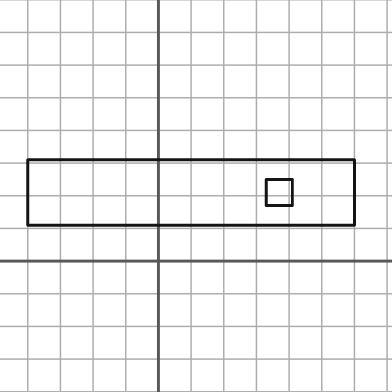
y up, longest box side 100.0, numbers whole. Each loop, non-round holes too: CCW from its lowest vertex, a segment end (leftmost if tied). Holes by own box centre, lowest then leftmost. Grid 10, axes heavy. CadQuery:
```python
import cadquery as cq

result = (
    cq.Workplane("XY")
    .moveTo(-40.0, 11.0)
    .lineTo(60.0, 11.0)
    .lineTo(60.0, 31.0)
    .lineTo(-40.0, 31.0)
    .close()
    .moveTo(33.0, 17.0)
    .lineTo(41.0, 17.0)
    .lineTo(41.0, 25.0)
    .lineTo(33.0, 25.0)
    .close()
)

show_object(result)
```